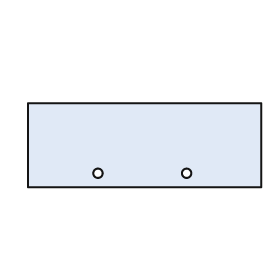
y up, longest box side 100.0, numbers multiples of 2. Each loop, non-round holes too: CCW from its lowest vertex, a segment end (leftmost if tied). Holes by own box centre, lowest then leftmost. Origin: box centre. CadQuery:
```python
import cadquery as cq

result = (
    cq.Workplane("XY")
    .moveTo(-50.0, -18.0)
    .lineTo(50.0, -18.0)
    .lineTo(50.0, 18.0)
    .lineTo(-50.0, 18.0)
    .close()
    .moveTo(-20.0, -12.0)
    .circle(2.0)
    .moveTo(18.0, -12.0)
    .circle(2.0)
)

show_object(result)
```